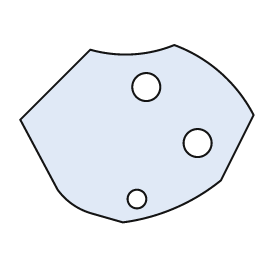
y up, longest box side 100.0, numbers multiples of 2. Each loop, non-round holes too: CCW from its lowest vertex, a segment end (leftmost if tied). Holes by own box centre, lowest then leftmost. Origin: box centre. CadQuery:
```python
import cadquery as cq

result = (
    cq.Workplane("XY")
    .moveTo(-6.0, -38.0)
    .threePointArc((16.0, -32.0), (36.0, -20.0))
    .lineTo(50.0, 8.0)
    .threePointArc((36.0, 26.0), (16.0, 38.0))
    .threePointArc((-2.0, 34.0), (-20.0, 36.0))
    .lineTo(-50.0, 6.0)
    .lineTo(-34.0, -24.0)
    .threePointArc((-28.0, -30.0), (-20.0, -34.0))
    .close()
    .moveTo(0.0, -28.0)
    .circle(4.0)
    .moveTo(26.0, -4.0)
    .circle(6.0)
    .moveTo(4.0, 20.0)
    .circle(6.0)
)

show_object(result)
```